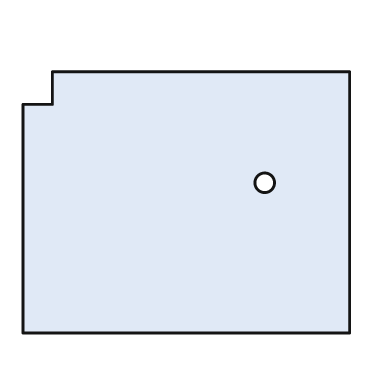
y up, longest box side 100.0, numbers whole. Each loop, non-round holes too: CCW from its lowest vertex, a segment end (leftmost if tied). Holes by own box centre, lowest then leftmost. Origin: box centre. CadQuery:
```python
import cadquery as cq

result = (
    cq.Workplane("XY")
    .moveTo(-50.0, -40.0)
    .lineTo(50.0, -40.0)
    .lineTo(50.0, 40.0)
    .lineTo(-41.0, 40.0)
    .lineTo(-41.0, 30.0)
    .lineTo(-50.0, 30.0)
    .close()
    .moveTo(24.0, 6.0)
    .circle(3.0)
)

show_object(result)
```